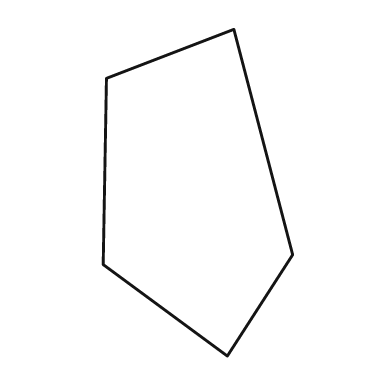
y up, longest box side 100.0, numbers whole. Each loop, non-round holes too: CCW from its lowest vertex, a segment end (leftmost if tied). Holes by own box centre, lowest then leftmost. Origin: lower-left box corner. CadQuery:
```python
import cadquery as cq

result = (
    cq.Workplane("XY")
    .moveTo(38.0, 0.0)
    .lineTo(58.0, 31.0)
    .lineTo(40.0, 100.0)
    .lineTo(1.0, 85.0)
    .lineTo(0.0, 28.0)
    .close()
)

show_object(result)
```